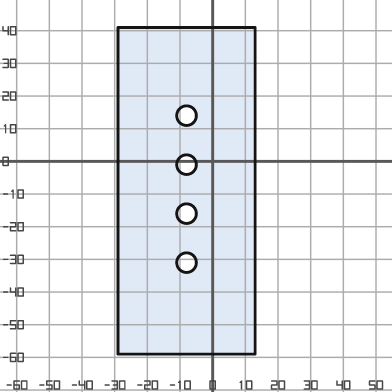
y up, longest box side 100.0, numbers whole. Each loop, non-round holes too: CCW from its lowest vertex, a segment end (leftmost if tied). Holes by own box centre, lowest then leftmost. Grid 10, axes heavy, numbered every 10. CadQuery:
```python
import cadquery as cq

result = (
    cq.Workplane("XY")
    .moveTo(-29.0, -59.0)
    .lineTo(13.0, -59.0)
    .lineTo(13.0, 41.0)
    .lineTo(-29.0, 41.0)
    .close()
    .moveTo(-8.0, -31.0)
    .circle(3.0)
    .moveTo(-8.0, -16.0)
    .circle(3.0)
    .moveTo(-8.0, -1.0)
    .circle(3.0)
    .moveTo(-8.0, 14.0)
    .circle(3.0)
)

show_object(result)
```